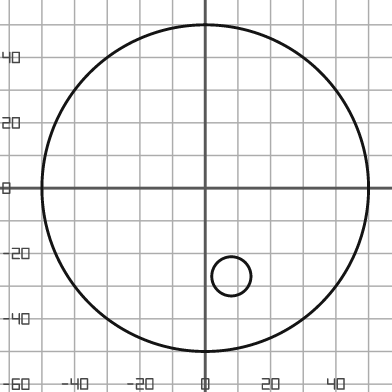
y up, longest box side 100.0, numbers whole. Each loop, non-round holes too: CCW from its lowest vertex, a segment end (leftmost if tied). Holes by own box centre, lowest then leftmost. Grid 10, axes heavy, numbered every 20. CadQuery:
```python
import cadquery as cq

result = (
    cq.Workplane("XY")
    .moveTo(0.0, 0.0)
    .circle(50.0)
    .moveTo(8.0, -27.0)
    .circle(6.0)
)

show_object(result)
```